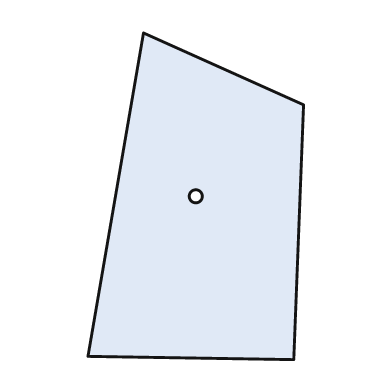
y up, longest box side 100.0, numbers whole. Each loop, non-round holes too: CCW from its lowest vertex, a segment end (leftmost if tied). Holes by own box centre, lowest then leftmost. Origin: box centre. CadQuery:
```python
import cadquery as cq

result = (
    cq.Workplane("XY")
    .moveTo(30.0, -50.0)
    .lineTo(33.0, 28.0)
    .lineTo(-16.0, 50.0)
    .lineTo(-33.0, -49.0)
    .close()
    .moveTo(0.0, 0.0)
    .circle(2.0)
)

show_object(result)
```